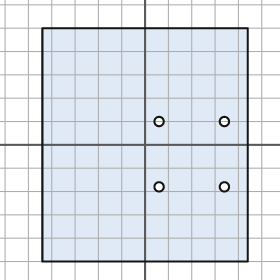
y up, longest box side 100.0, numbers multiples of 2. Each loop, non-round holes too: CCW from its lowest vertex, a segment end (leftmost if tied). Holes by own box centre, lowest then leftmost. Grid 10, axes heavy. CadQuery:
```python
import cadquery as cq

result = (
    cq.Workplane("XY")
    .moveTo(-44.0, -50.0)
    .lineTo(44.0, -50.0)
    .lineTo(44.0, 50.0)
    .lineTo(-44.0, 50.0)
    .close()
    .moveTo(6.0, -18.0)
    .circle(2.0)
    .moveTo(34.0, -18.0)
    .circle(2.0)
    .moveTo(6.0, 10.0)
    .circle(2.0)
    .moveTo(34.0, 10.0)
    .circle(2.0)
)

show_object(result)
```